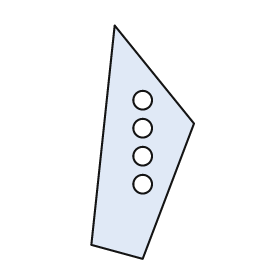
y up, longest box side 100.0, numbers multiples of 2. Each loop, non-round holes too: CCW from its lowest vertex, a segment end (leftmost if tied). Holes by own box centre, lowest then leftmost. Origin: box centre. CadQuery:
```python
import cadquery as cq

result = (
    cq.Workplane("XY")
    .moveTo(0.0, -50.0)
    .lineTo(22.0, 8.0)
    .lineTo(-12.0, 50.0)
    .lineTo(-22.0, -44.0)
    .close()
    .moveTo(0.0, -18.0)
    .circle(4.0)
    .moveTo(0.0, -6.0)
    .circle(4.0)
    .moveTo(0.0, 6.0)
    .circle(4.0)
    .moveTo(0.0, 18.0)
    .circle(4.0)
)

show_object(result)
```